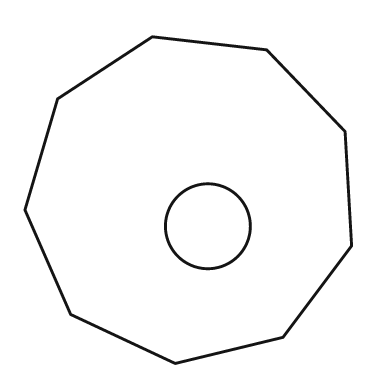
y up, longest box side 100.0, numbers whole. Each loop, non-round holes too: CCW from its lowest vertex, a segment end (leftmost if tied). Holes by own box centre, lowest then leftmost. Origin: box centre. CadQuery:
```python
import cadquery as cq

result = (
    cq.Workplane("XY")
    .moveTo(-4.0, -50.0)
    .lineTo(29.0, -42.0)
    .lineTo(50.0, -14.0)
    .lineTo(48.0, 21.0)
    .lineTo(24.0, 46.0)
    .lineTo(-11.0, 50.0)
    .lineTo(-40.0, 31.0)
    .lineTo(-50.0, -3.0)
    .lineTo(-36.0, -35.0)
    .close()
    .moveTo(6.0, -8.0)
    .circle(13.0)
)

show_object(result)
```